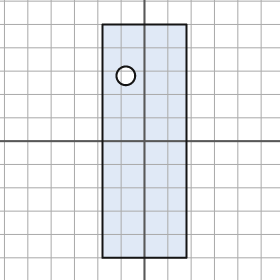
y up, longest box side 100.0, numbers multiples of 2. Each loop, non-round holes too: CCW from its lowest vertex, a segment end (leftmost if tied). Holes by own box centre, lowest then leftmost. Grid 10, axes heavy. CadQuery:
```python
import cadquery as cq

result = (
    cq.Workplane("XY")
    .moveTo(-18.0, -50.0)
    .lineTo(18.0, -50.0)
    .lineTo(18.0, 50.0)
    .lineTo(-18.0, 50.0)
    .close()
    .moveTo(-8.0, 28.0)
    .circle(4.0)
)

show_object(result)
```